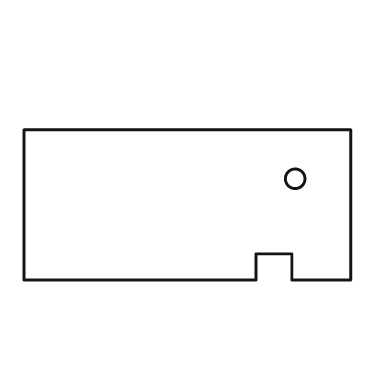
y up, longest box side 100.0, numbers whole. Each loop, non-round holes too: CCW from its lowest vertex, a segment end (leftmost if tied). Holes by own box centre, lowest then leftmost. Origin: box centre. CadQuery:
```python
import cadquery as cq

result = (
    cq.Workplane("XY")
    .moveTo(-50.0, -23.0)
    .lineTo(21.0, -23.0)
    .lineTo(21.0, -15.0)
    .lineTo(32.0, -15.0)
    .lineTo(32.0, -23.0)
    .lineTo(50.0, -23.0)
    .lineTo(50.0, 23.0)
    .lineTo(-50.0, 23.0)
    .close()
    .moveTo(33.0, 8.0)
    .circle(3.0)
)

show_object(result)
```